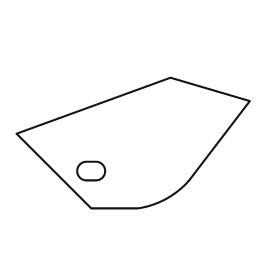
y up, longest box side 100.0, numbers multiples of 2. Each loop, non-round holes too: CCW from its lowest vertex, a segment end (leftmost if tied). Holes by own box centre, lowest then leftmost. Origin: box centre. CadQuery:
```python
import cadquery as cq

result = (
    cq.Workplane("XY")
    .moveTo(-18.0, -28.0)
    .lineTo(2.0, -28.0)
    .threePointArc((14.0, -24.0), (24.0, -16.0))
    .lineTo(50.0, 18.0)
    .lineTo(16.0, 28.0)
    .lineTo(-50.0, 4.0)
    .close()
    .moveTo(-20.0, -16.0)
    .lineTo(-16.0, -16.0)
    .threePointArc((-12.0, -12.0), (-16.0, -8.0))
    .lineTo(-20.0, -8.0)
    .threePointArc((-24.0, -12.0), (-20.0, -16.0))
    .close()
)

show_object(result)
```